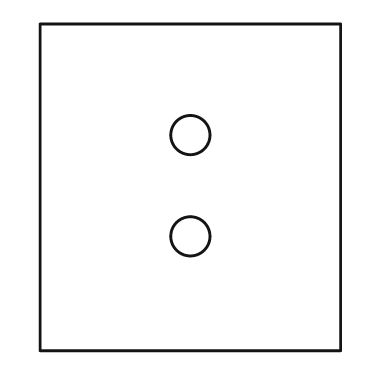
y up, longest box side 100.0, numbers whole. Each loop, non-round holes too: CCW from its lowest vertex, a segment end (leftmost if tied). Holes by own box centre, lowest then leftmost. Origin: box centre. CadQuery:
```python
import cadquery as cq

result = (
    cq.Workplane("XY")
    .moveTo(-46.0, -50.0)
    .lineTo(46.0, -50.0)
    .lineTo(46.0, 50.0)
    .lineTo(-46.0, 50.0)
    .close()
    .moveTo(0.0, -15.0)
    .circle(6.0)
    .moveTo(0.0, 16.0)
    .circle(6.0)
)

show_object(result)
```